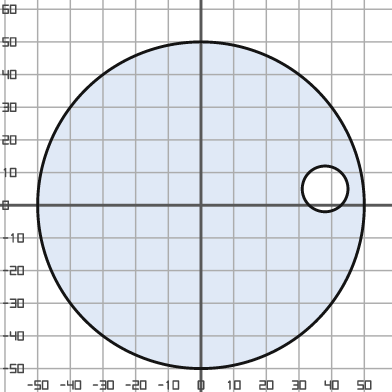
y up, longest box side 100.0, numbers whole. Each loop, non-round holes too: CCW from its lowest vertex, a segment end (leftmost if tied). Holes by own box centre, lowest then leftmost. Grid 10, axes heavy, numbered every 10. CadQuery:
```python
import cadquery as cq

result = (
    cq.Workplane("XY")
    .moveTo(0.0, 0.0)
    .circle(50.0)
    .moveTo(38.0, 5.0)
    .circle(7.0)
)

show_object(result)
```